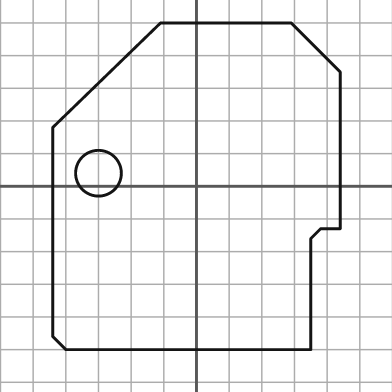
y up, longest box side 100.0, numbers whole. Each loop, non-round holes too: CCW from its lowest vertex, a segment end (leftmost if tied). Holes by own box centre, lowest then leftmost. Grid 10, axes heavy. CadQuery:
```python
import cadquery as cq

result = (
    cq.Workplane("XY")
    .moveTo(-40.0, -50.0)
    .lineTo(35.0, -50.0)
    .lineTo(35.0, -16.0)
    .lineTo(38.0, -13.0)
    .lineTo(44.0, -13.0)
    .lineTo(44.0, 35.0)
    .lineTo(29.0, 50.0)
    .lineTo(-11.0, 50.0)
    .lineTo(-44.0, 18.0)
    .lineTo(-44.0, -46.0)
    .close()
    .moveTo(-30.0, 4.0)
    .circle(7.0)
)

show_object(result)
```